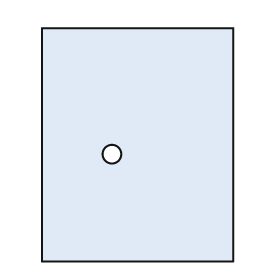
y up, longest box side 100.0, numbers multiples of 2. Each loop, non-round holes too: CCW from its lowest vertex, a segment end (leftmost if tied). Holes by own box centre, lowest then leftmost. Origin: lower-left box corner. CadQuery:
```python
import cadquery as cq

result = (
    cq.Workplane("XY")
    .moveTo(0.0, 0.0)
    .lineTo(82.0, 0.0)
    .lineTo(82.0, 100.0)
    .lineTo(0.0, 100.0)
    .close()
    .moveTo(30.0, 46.0)
    .circle(4.0)
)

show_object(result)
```